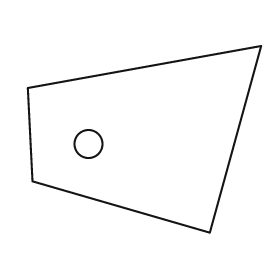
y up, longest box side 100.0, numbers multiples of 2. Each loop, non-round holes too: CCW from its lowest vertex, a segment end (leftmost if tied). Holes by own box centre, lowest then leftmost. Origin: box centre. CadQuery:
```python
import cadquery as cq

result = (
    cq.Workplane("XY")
    .moveTo(28.0, -40.0)
    .lineTo(50.0, 40.0)
    .lineTo(-50.0, 22.0)
    .lineTo(-48.0, -18.0)
    .close()
    .moveTo(-24.0, -2.0)
    .circle(6.0)
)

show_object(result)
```